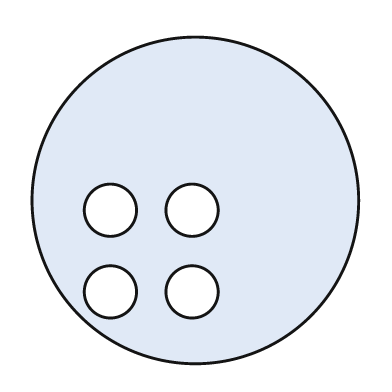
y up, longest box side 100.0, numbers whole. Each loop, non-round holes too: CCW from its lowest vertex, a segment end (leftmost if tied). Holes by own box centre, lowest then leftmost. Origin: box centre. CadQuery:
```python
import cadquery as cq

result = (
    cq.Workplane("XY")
    .moveTo(0.0, 0.0)
    .circle(50.0)
    .moveTo(-26.0, -28.0)
    .circle(8.0)
    .moveTo(-1.0, -28.0)
    .circle(8.0)
    .moveTo(-26.0, -3.0)
    .circle(8.0)
    .moveTo(-1.0, -3.0)
    .circle(8.0)
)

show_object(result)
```